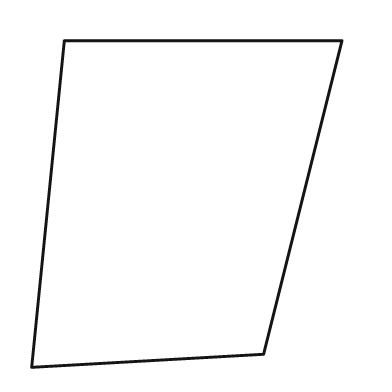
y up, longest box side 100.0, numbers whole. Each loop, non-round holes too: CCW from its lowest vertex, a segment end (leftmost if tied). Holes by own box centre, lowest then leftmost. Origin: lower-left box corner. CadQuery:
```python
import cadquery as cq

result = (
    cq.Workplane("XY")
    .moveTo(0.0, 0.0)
    .lineTo(71.0, 4.0)
    .lineTo(95.0, 100.0)
    .lineTo(10.0, 100.0)
    .close()
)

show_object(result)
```